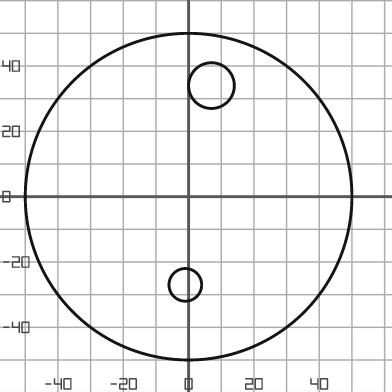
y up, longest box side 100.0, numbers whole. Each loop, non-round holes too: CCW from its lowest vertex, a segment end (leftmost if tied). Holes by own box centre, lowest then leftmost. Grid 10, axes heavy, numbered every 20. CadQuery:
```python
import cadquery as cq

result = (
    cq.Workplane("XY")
    .moveTo(0.0, 0.0)
    .circle(50.0)
    .moveTo(-1.0, -27.0)
    .circle(5.0)
    .moveTo(7.0, 34.0)
    .circle(7.0)
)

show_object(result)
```